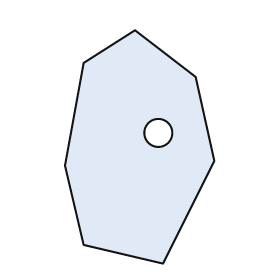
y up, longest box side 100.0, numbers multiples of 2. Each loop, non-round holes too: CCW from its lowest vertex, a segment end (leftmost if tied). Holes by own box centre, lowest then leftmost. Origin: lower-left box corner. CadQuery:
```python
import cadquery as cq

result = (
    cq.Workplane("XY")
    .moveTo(42.0, 0.0)
    .lineTo(64.0, 44.0)
    .lineTo(56.0, 80.0)
    .lineTo(30.0, 100.0)
    .lineTo(8.0, 86.0)
    .lineTo(0.0, 42.0)
    .lineTo(8.0, 8.0)
    .close()
    .moveTo(40.0, 56.0)
    .circle(6.0)
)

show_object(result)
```